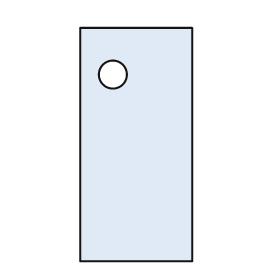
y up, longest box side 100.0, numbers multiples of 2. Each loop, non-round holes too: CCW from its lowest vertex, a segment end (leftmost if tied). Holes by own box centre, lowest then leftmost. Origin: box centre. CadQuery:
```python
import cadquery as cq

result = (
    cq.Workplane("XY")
    .moveTo(-24.0, -50.0)
    .lineTo(24.0, -50.0)
    .lineTo(24.0, 50.0)
    .lineTo(-24.0, 50.0)
    .close()
    .moveTo(-10.0, 30.0)
    .circle(6.0)
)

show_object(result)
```